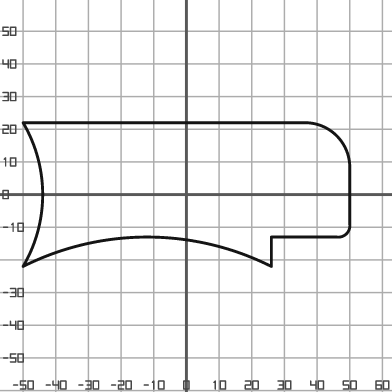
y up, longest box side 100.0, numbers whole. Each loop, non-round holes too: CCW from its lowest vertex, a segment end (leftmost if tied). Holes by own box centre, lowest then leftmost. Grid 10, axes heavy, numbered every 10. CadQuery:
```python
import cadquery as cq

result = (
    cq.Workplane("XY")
    .moveTo(-50.0, -22.0)
    .threePointArc((-12.0, -13.0), (26.0, -22.0))
    .lineTo(26.0, -13.0)
    .lineTo(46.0, -13.0)
    .threePointArc((49.0, -12.0), (50.0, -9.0))
    .lineTo(50.0, 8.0)
    .threePointArc((46.0, 18.0), (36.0, 22.0))
    .lineTo(-50.0, 22.0)
    .threePointArc((-44.0, 0.0), (-50.0, -22.0))
    .close()
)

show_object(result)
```